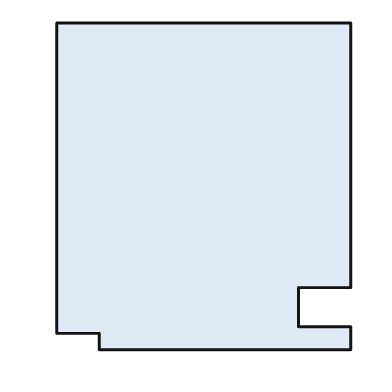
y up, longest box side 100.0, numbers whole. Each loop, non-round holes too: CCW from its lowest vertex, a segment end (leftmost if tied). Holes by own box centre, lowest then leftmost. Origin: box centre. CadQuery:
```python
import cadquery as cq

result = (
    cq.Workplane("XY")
    .moveTo(-32.0, -50.0)
    .lineTo(45.0, -50.0)
    .lineTo(45.0, -43.0)
    .lineTo(29.0, -43.0)
    .lineTo(29.0, -31.0)
    .lineTo(45.0, -31.0)
    .lineTo(45.0, 50.0)
    .lineTo(-45.0, 50.0)
    .lineTo(-45.0, -45.0)
    .lineTo(-32.0, -45.0)
    .close()
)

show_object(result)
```